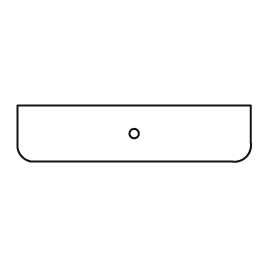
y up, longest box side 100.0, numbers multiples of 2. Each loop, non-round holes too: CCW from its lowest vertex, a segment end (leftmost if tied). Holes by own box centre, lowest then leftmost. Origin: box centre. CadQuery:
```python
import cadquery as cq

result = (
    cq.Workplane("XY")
    .moveTo(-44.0, -12.0)
    .lineTo(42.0, -12.0)
    .threePointArc((48.0, -10.0), (50.0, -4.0))
    .lineTo(50.0, 12.0)
    .lineTo(-50.0, 12.0)
    .lineTo(-50.0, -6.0)
    .threePointArc((-48.0, -10.0), (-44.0, -12.0))
    .close()
    .moveTo(0.0, 0.0)
    .circle(2.0)
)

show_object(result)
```